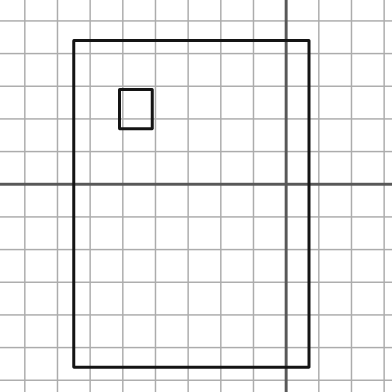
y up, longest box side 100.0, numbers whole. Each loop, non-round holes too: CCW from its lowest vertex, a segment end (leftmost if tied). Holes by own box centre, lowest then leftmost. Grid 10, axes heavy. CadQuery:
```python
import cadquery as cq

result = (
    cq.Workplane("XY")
    .moveTo(-65.0, -56.0)
    .lineTo(7.0, -56.0)
    .lineTo(7.0, 44.0)
    .lineTo(-65.0, 44.0)
    .close()
    .moveTo(-51.0, 17.0)
    .lineTo(-41.0, 17.0)
    .lineTo(-41.0, 29.0)
    .lineTo(-51.0, 29.0)
    .close()
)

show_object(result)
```